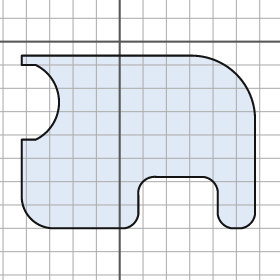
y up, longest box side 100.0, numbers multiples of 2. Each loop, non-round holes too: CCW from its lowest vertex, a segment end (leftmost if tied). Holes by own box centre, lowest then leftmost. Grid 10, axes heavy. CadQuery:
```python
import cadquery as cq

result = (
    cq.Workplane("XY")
    .moveTo(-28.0, -80.0)
    .lineTo(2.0, -80.0)
    .threePointArc((6.0, -78.0), (8.0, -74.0))
    .lineTo(8.0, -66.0)
    .threePointArc((10.0, -60.0), (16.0, -58.0))
    .lineTo(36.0, -58.0)
    .threePointArc((40.0, -60.0), (42.0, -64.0))
    .lineTo(42.0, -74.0)
    .threePointArc((44.0, -78.0), (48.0, -80.0))
    .lineTo(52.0, -80.0)
    .threePointArc((56.0, -78.0), (58.0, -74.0))
    .lineTo(58.0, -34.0)
    .threePointArc((50.0, -14.0), (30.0, -6.0))
    .lineTo(-42.0, -6.0)
    .lineTo(-42.0, -10.0)
    .lineTo(-36.0, -10.0)
    .threePointArc((-26.0, -26.0), (-36.0, -42.0))
    .lineTo(-42.0, -42.0)
    .lineTo(-42.0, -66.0)
    .threePointArc((-38.0, -76.0), (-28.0, -80.0))
    .close()
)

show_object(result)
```